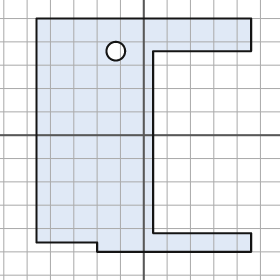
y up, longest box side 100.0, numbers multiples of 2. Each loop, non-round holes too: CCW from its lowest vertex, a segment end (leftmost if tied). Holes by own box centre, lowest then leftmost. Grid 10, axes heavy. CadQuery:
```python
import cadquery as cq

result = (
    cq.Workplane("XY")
    .moveTo(-20.0, -50.0)
    .lineTo(46.0, -50.0)
    .lineTo(46.0, -42.0)
    .lineTo(4.0, -42.0)
    .lineTo(4.0, 36.0)
    .lineTo(46.0, 36.0)
    .lineTo(46.0, 50.0)
    .lineTo(-46.0, 50.0)
    .lineTo(-46.0, -46.0)
    .lineTo(-20.0, -46.0)
    .close()
    .moveTo(-12.0, 36.0)
    .circle(4.0)
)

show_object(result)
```